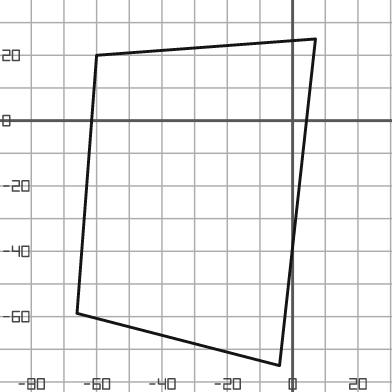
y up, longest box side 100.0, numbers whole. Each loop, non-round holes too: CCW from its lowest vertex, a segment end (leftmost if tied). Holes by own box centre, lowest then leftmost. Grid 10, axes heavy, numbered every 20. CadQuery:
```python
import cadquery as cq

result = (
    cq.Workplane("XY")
    .moveTo(-4.0, -75.0)
    .lineTo(7.0, 25.0)
    .lineTo(-60.0, 20.0)
    .lineTo(-66.0, -59.0)
    .close()
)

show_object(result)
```